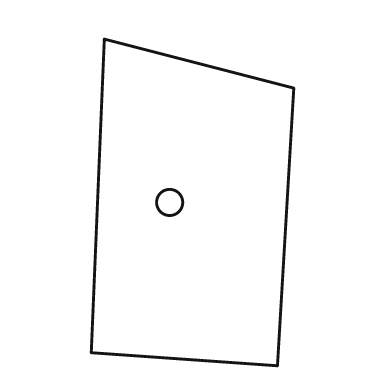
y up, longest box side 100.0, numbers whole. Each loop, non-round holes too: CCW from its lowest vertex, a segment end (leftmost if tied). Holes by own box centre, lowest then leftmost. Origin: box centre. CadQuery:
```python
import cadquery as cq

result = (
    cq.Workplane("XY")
    .moveTo(26.0, -50.0)
    .lineTo(31.0, 35.0)
    .lineTo(-27.0, 50.0)
    .lineTo(-31.0, -46.0)
    .close()
    .moveTo(-7.0, 0.0)
    .circle(4.0)
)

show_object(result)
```